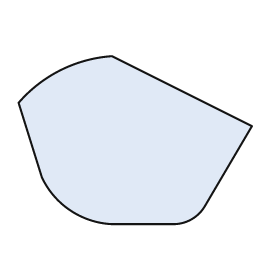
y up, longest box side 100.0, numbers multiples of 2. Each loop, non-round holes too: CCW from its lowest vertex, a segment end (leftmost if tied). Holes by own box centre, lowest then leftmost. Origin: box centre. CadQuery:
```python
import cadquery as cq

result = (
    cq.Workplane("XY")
    .moveTo(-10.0, -36.0)
    .lineTo(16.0, -36.0)
    .threePointArc((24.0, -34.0), (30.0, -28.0))
    .lineTo(50.0, 6.0)
    .lineTo(-10.0, 36.0)
    .threePointArc((-32.0, 30.0), (-50.0, 16.0))
    .lineTo(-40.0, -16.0)
    .threePointArc((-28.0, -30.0), (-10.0, -36.0))
    .close()
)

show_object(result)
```